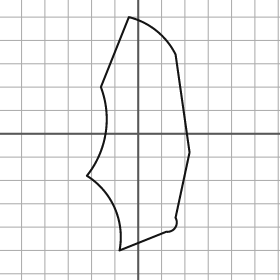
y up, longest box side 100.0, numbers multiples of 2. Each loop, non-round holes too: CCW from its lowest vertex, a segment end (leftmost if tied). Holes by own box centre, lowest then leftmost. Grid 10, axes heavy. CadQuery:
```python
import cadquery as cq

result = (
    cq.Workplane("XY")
    .moveTo(-8.0, -50.0)
    .lineTo(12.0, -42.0)
    .threePointArc((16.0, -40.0), (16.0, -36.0))
    .lineTo(22.0, -8.0)
    .lineTo(16.0, 34.0)
    .threePointArc((8.0, 44.0), (-4.0, 50.0))
    .lineTo(-16.0, 20.0)
    .threePointArc((-14.0, 0.0), (-22.0, -18.0))
    .threePointArc((-10.0, -32.0), (-8.0, -50.0))
    .close()
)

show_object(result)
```